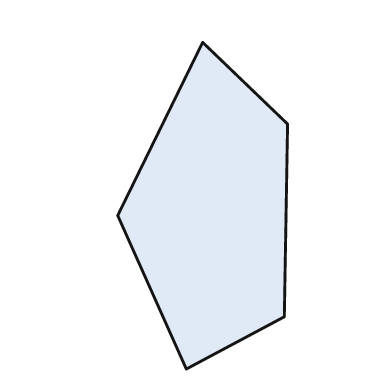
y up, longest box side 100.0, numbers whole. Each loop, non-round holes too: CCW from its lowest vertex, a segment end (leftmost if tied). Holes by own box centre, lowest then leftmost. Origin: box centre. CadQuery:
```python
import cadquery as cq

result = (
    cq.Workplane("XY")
    .moveTo(-5.0, -50.0)
    .lineTo(25.0, -34.0)
    .lineTo(26.0, 25.0)
    .lineTo(0.0, 50.0)
    .lineTo(-26.0, -3.0)
    .close()
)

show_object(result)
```